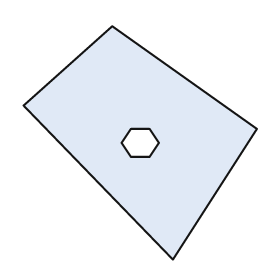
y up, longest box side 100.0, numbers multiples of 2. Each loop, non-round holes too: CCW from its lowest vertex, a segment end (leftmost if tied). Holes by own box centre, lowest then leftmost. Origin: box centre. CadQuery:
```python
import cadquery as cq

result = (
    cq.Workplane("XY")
    .moveTo(14.0, -50.0)
    .lineTo(50.0, 6.0)
    .lineTo(-12.0, 50.0)
    .lineTo(-50.0, 16.0)
    .close()
    .moveTo(-4.0, -6.0)
    .lineTo(4.0, -6.0)
    .lineTo(8.0, 0.0)
    .lineTo(4.0, 6.0)
    .lineTo(-4.0, 6.0)
    .lineTo(-8.0, 0.0)
    .close()
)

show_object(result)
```